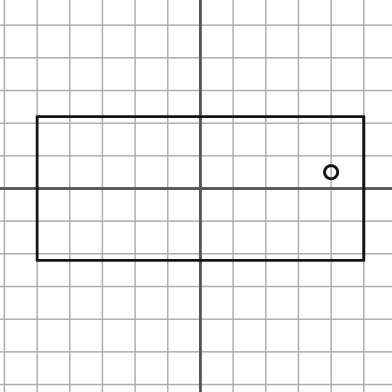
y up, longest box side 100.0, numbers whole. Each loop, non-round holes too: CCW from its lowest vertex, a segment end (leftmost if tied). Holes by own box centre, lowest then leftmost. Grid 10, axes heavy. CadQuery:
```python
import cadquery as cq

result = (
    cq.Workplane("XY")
    .moveTo(-50.0, -22.0)
    .lineTo(50.0, -22.0)
    .lineTo(50.0, 22.0)
    .lineTo(-50.0, 22.0)
    .close()
    .moveTo(40.0, 5.0)
    .circle(2.0)
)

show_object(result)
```